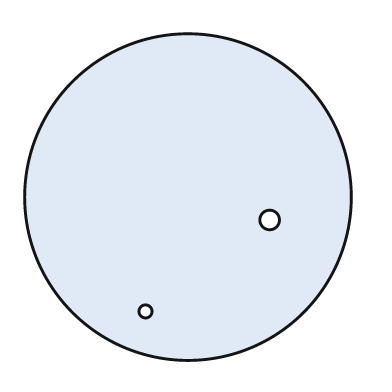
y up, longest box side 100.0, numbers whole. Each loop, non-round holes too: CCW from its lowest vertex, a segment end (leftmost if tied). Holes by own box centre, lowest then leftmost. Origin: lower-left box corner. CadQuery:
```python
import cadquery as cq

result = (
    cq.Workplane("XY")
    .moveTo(50.0, 50.0)
    .circle(50.0)
    .moveTo(37.0, 15.0)
    .circle(2.0)
    .moveTo(75.0, 43.0)
    .circle(3.0)
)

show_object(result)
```